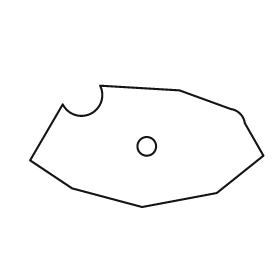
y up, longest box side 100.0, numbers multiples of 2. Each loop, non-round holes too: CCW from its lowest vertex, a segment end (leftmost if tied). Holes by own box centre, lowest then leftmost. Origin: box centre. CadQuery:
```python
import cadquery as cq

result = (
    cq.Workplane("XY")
    .moveTo(-2.0, -26.0)
    .lineTo(30.0, -20.0)
    .lineTo(50.0, -4.0)
    .lineTo(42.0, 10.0)
    .threePointArc((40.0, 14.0), (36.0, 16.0))
    .lineTo(14.0, 24.0)
    .lineTo(-20.0, 26.0)
    .threePointArc((-24.0, 14.0), (-36.0, 18.0))
    .lineTo(-50.0, -6.0)
    .lineTo(-32.0, -18.0)
    .close()
    .moveTo(0.0, 0.0)
    .circle(4.0)
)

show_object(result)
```